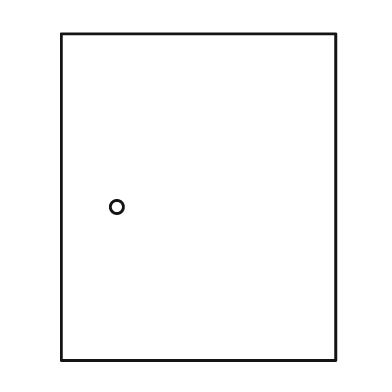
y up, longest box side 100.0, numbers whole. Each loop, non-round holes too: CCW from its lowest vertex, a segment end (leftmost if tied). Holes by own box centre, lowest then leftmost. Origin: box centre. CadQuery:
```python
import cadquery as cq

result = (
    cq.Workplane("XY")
    .moveTo(-42.0, -50.0)
    .lineTo(42.0, -50.0)
    .lineTo(42.0, 50.0)
    .lineTo(-42.0, 50.0)
    .close()
    .moveTo(-25.0, -3.0)
    .circle(2.0)
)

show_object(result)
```